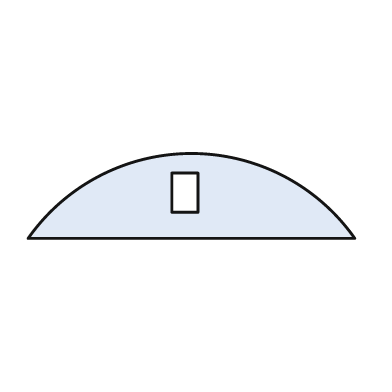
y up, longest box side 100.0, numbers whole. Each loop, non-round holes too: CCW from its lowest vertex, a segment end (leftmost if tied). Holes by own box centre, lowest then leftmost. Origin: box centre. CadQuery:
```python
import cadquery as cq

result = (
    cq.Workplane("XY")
    .moveTo(-50.0, -13.0)
    .lineTo(50.0, -13.0)
    .threePointArc((0.0, 13.0), (-50.0, -13.0))
    .close()
    .moveTo(-6.0, -5.0)
    .lineTo(2.0, -5.0)
    .lineTo(2.0, 7.0)
    .lineTo(-6.0, 7.0)
    .close()
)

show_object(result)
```